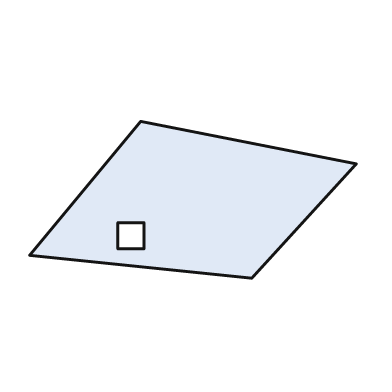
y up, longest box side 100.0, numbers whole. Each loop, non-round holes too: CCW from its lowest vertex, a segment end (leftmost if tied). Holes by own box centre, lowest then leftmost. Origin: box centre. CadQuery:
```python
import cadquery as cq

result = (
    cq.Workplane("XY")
    .moveTo(18.0, -24.0)
    .lineTo(50.0, 11.0)
    .lineTo(-16.0, 24.0)
    .lineTo(-50.0, -17.0)
    .close()
    .moveTo(-23.0, -15.0)
    .lineTo(-15.0, -15.0)
    .lineTo(-15.0, -7.0)
    .lineTo(-23.0, -7.0)
    .close()
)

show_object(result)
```